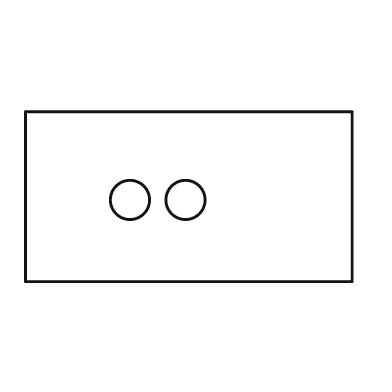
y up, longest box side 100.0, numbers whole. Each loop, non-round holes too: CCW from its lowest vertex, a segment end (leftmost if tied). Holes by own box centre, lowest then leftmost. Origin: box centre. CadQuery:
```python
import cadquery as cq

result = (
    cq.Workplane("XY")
    .moveTo(-50.0, -26.0)
    .lineTo(50.0, -26.0)
    .lineTo(50.0, 26.0)
    .lineTo(-50.0, 26.0)
    .close()
    .moveTo(-18.0, -1.0)
    .circle(6.0)
    .moveTo(-1.0, -1.0)
    .circle(6.0)
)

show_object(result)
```